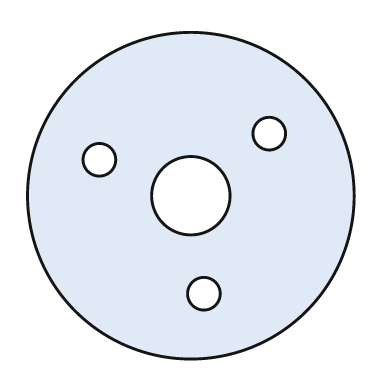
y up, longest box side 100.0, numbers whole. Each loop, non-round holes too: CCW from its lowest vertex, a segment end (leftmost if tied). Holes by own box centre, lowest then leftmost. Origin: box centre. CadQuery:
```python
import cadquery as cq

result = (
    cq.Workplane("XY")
    .moveTo(0.0, 0.0)
    .circle(50.0)
    .moveTo(4.0, -30.0)
    .circle(5.0)
    .moveTo(0.0, 0.0)
    .circle(12.0)
    .moveTo(-28.0, 11.0)
    .circle(5.0)
    .moveTo(24.0, 19.0)
    .circle(5.0)
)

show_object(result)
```